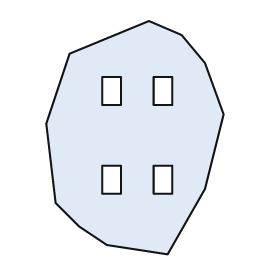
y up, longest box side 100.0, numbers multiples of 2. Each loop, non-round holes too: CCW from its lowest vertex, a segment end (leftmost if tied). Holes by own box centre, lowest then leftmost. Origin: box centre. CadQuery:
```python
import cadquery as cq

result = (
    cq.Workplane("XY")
    .moveTo(14.0, -50.0)
    .lineTo(30.0, -22.0)
    .lineTo(38.0, 10.0)
    .lineTo(30.0, 32.0)
    .lineTo(20.0, 44.0)
    .lineTo(6.0, 50.0)
    .lineTo(-28.0, 36.0)
    .lineTo(-38.0, 6.0)
    .lineTo(-34.0, -28.0)
    .lineTo(-24.0, -38.0)
    .lineTo(-12.0, -46.0)
    .close()
    .moveTo(-14.0, -24.0)
    .lineTo(-6.0, -24.0)
    .lineTo(-6.0, -12.0)
    .lineTo(-14.0, -12.0)
    .close()
    .moveTo(8.0, -24.0)
    .lineTo(16.0, -24.0)
    .lineTo(16.0, -12.0)
    .lineTo(8.0, -12.0)
    .close()
    .moveTo(-14.0, 14.0)
    .lineTo(-6.0, 14.0)
    .lineTo(-6.0, 26.0)
    .lineTo(-14.0, 26.0)
    .close()
    .moveTo(8.0, 14.0)
    .lineTo(16.0, 14.0)
    .lineTo(16.0, 26.0)
    .lineTo(8.0, 26.0)
    .close()
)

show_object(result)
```